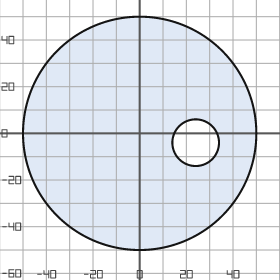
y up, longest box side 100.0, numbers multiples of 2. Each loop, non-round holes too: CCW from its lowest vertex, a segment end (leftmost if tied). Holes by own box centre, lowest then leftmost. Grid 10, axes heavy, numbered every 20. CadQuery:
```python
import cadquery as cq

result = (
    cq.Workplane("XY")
    .moveTo(0.0, 0.0)
    .circle(50.0)
    .moveTo(24.0, -4.0)
    .circle(10.0)
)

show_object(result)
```